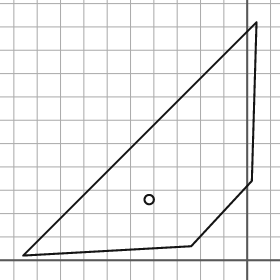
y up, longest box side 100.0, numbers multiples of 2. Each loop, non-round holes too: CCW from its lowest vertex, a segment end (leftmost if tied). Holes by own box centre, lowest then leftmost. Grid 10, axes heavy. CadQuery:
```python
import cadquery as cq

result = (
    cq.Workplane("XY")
    .moveTo(-96.0, 2.0)
    .lineTo(-24.0, 6.0)
    .lineTo(2.0, 34.0)
    .lineTo(4.0, 102.0)
    .close()
    .moveTo(-42.0, 26.0)
    .circle(2.0)
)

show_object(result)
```